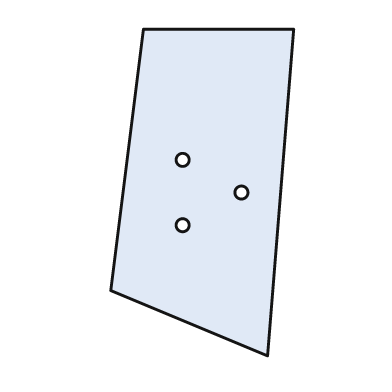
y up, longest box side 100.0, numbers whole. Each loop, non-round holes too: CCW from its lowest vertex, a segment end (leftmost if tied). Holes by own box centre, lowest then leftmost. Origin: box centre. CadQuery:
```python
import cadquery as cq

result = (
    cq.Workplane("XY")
    .moveTo(20.0, -50.0)
    .lineTo(28.0, 50.0)
    .lineTo(-18.0, 50.0)
    .lineTo(-28.0, -30.0)
    .close()
    .moveTo(-6.0, -10.0)
    .circle(2.0)
    .moveTo(12.0, 0.0)
    .circle(2.0)
    .moveTo(-6.0, 10.0)
    .circle(2.0)
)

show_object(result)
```